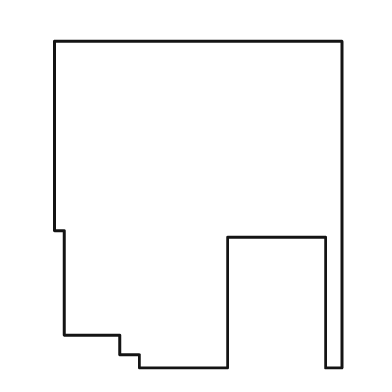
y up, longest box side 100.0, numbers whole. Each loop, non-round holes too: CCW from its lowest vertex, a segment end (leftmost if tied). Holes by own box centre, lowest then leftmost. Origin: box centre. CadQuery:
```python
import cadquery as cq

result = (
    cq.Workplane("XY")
    .moveTo(-18.0, -50.0)
    .lineTo(9.0, -50.0)
    .lineTo(9.0, -10.0)
    .lineTo(39.0, -10.0)
    .lineTo(39.0, -50.0)
    .lineTo(44.0, -50.0)
    .lineTo(44.0, 50.0)
    .lineTo(-44.0, 50.0)
    .lineTo(-44.0, -8.0)
    .lineTo(-41.0, -8.0)
    .lineTo(-41.0, -40.0)
    .lineTo(-24.0, -40.0)
    .lineTo(-24.0, -46.0)
    .lineTo(-18.0, -46.0)
    .close()
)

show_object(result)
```